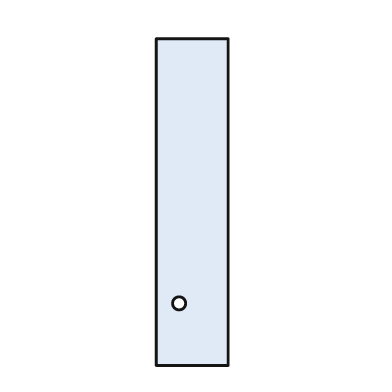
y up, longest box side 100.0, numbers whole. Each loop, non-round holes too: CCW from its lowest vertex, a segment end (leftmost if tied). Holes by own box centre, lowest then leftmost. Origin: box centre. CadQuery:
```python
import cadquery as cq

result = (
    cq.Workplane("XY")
    .moveTo(-11.0, -50.0)
    .lineTo(11.0, -50.0)
    .lineTo(11.0, 50.0)
    .lineTo(-11.0, 50.0)
    .close()
    .moveTo(-4.0, -31.0)
    .circle(2.0)
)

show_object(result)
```